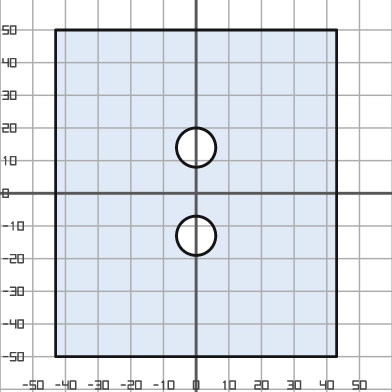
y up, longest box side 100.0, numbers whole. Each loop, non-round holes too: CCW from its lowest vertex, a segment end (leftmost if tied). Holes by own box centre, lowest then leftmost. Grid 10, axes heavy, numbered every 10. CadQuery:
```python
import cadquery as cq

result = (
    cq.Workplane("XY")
    .moveTo(-43.0, -50.0)
    .lineTo(43.0, -50.0)
    .lineTo(43.0, 50.0)
    .lineTo(-43.0, 50.0)
    .close()
    .moveTo(0.0, -13.0)
    .circle(6.0)
    .moveTo(0.0, 14.0)
    .circle(6.0)
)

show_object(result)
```